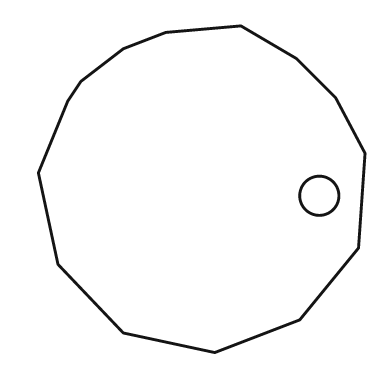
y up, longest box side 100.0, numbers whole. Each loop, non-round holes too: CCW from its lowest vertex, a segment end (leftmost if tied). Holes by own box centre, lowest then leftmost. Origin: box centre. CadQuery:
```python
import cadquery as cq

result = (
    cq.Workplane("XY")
    .moveTo(4.0, -50.0)
    .lineTo(30.0, -40.0)
    .lineTo(48.0, -18.0)
    .lineTo(50.0, 11.0)
    .lineTo(41.0, 28.0)
    .lineTo(29.0, 40.0)
    .lineTo(12.0, 50.0)
    .lineTo(-11.0, 48.0)
    .lineTo(-24.0, 43.0)
    .lineTo(-37.0, 33.0)
    .lineTo(-41.0, 27.0)
    .lineTo(-50.0, 5.0)
    .lineTo(-44.0, -23.0)
    .lineTo(-24.0, -44.0)
    .close()
    .moveTo(36.0, -2.0)
    .circle(6.0)
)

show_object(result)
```